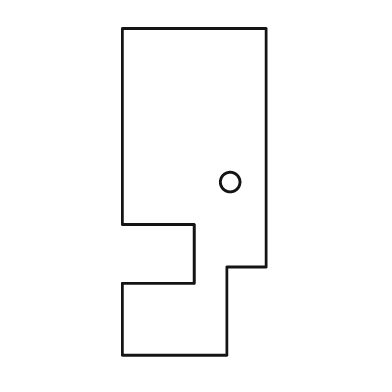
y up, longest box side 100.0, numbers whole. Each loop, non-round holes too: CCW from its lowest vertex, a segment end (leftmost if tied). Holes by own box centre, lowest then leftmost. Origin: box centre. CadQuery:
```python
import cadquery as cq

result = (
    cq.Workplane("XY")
    .moveTo(-22.0, -50.0)
    .lineTo(10.0, -50.0)
    .lineTo(10.0, -23.0)
    .lineTo(22.0, -23.0)
    .lineTo(22.0, 50.0)
    .lineTo(-22.0, 50.0)
    .lineTo(-22.0, -10.0)
    .lineTo(0.0, -10.0)
    .lineTo(0.0, -28.0)
    .lineTo(-22.0, -28.0)
    .close()
    .moveTo(11.0, 3.0)
    .circle(3.0)
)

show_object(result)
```